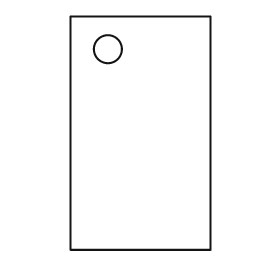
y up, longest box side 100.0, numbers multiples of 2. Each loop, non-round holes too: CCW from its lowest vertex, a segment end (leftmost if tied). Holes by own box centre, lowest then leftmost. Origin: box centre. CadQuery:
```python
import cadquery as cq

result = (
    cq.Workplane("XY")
    .moveTo(-30.0, -50.0)
    .lineTo(30.0, -50.0)
    .lineTo(30.0, 50.0)
    .lineTo(-30.0, 50.0)
    .close()
    .moveTo(-14.0, 36.0)
    .circle(6.0)
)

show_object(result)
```